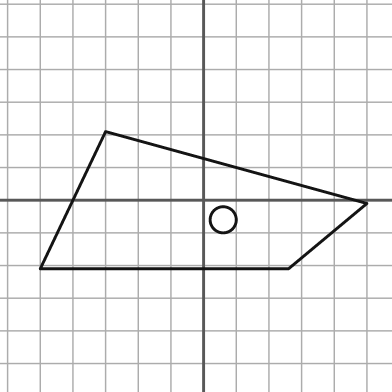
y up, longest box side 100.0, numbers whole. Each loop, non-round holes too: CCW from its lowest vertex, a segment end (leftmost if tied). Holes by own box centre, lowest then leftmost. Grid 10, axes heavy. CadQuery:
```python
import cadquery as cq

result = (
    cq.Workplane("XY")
    .moveTo(-50.0, -21.0)
    .lineTo(26.0, -21.0)
    .lineTo(50.0, -1.0)
    .lineTo(-30.0, 21.0)
    .close()
    .moveTo(6.0, -6.0)
    .circle(4.0)
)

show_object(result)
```